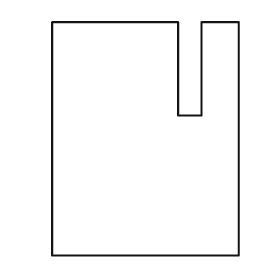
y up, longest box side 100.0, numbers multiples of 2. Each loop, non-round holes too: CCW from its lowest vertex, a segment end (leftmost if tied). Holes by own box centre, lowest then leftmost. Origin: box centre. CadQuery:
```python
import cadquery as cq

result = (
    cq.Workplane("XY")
    .moveTo(-40.0, -50.0)
    .lineTo(40.0, -50.0)
    .lineTo(40.0, 50.0)
    .lineTo(24.0, 50.0)
    .lineTo(24.0, 10.0)
    .lineTo(14.0, 10.0)
    .lineTo(14.0, 50.0)
    .lineTo(-40.0, 50.0)
    .close()
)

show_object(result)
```